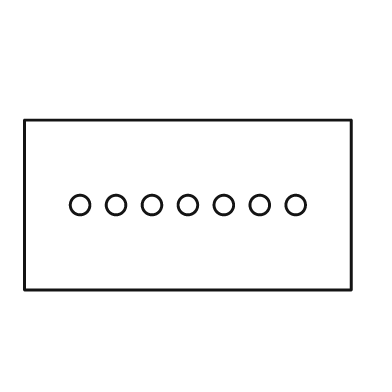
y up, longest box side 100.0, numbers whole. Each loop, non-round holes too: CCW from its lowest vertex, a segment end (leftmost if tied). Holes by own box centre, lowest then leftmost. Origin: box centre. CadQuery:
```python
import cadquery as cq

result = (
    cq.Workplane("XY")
    .moveTo(-50.0, -26.0)
    .lineTo(50.0, -26.0)
    .lineTo(50.0, 26.0)
    .lineTo(-50.0, 26.0)
    .close()
    .moveTo(-33.0, 0.0)
    .circle(3.0)
    .moveTo(-22.0, 0.0)
    .circle(3.0)
    .moveTo(-11.0, 0.0)
    .circle(3.0)
    .moveTo(0.0, 0.0)
    .circle(3.0)
    .moveTo(11.0, 0.0)
    .circle(3.0)
    .moveTo(22.0, 0.0)
    .circle(3.0)
    .moveTo(33.0, 0.0)
    .circle(3.0)
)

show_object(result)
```